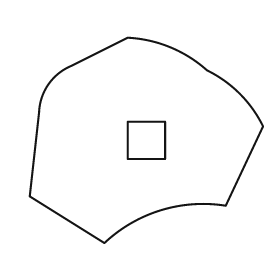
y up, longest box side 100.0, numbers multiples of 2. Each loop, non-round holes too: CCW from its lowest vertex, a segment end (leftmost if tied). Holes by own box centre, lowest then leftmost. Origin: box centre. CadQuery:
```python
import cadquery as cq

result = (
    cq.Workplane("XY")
    .moveTo(-18.0, -44.0)
    .threePointArc((6.0, -30.0), (34.0, -28.0))
    .lineTo(50.0, 6.0)
    .threePointArc((40.0, 20.0), (26.0, 30.0))
    .threePointArc((10.0, 40.0), (-8.0, 44.0))
    .lineTo(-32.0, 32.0)
    .threePointArc((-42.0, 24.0), (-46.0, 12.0))
    .lineTo(-50.0, -24.0)
    .close()
    .moveTo(-8.0, -8.0)
    .lineTo(8.0, -8.0)
    .lineTo(8.0, 8.0)
    .lineTo(-8.0, 8.0)
    .close()
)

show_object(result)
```